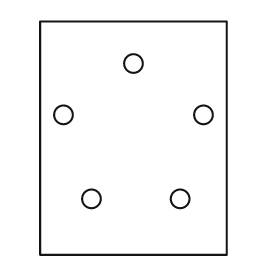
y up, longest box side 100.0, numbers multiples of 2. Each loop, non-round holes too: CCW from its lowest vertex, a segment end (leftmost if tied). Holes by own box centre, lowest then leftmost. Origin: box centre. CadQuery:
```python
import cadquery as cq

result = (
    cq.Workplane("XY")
    .moveTo(-40.0, -50.0)
    .lineTo(40.0, -50.0)
    .lineTo(40.0, 50.0)
    .lineTo(-40.0, 50.0)
    .close()
    .moveTo(-18.0, -26.0)
    .circle(4.0)
    .moveTo(20.0, -26.0)
    .circle(4.0)
    .moveTo(-30.0, 10.0)
    .circle(4.0)
    .moveTo(30.0, 10.0)
    .circle(4.0)
    .moveTo(0.0, 32.0)
    .circle(4.0)
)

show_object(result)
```